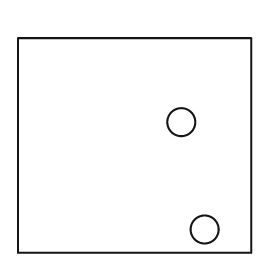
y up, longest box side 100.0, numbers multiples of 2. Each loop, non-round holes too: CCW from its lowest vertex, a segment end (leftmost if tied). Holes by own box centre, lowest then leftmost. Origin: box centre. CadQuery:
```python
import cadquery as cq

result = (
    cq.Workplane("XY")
    .moveTo(-50.0, -46.0)
    .lineTo(50.0, -46.0)
    .lineTo(50.0, 46.0)
    .lineTo(-50.0, 46.0)
    .close()
    .moveTo(30.0, -36.0)
    .circle(6.0)
    .moveTo(20.0, 10.0)
    .circle(6.0)
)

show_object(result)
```